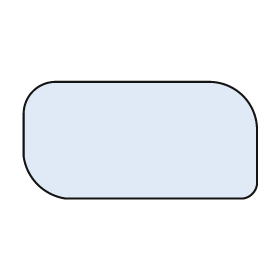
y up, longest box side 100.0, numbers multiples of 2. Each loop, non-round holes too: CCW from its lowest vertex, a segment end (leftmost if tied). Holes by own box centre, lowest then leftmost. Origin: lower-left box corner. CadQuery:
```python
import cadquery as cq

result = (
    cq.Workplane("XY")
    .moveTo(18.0, 0.0)
    .lineTo(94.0, 0.0)
    .threePointArc((98.0, 2.0), (100.0, 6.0))
    .lineTo(100.0, 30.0)
    .threePointArc((94.0, 44.0), (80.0, 50.0))
    .lineTo(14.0, 50.0)
    .threePointArc((4.0, 46.0), (0.0, 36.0))
    .lineTo(0.0, 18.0)
    .threePointArc((6.0, 6.0), (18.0, 0.0))
    .close()
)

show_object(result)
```